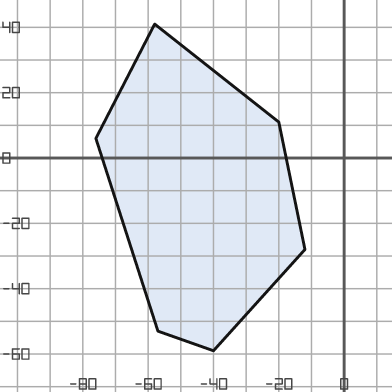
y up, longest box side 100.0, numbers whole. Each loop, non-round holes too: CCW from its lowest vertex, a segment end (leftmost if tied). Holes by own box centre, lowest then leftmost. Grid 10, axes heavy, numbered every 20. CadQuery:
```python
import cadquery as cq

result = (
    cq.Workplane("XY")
    .moveTo(-40.0, -59.0)
    .lineTo(-12.0, -28.0)
    .lineTo(-20.0, 11.0)
    .lineTo(-58.0, 41.0)
    .lineTo(-76.0, 6.0)
    .lineTo(-57.0, -53.0)
    .close()
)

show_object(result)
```